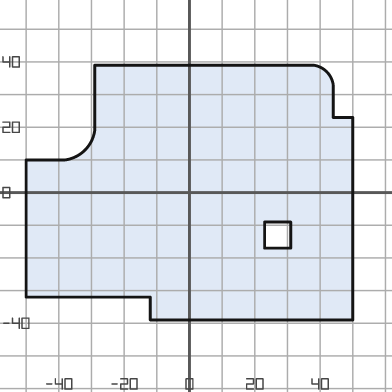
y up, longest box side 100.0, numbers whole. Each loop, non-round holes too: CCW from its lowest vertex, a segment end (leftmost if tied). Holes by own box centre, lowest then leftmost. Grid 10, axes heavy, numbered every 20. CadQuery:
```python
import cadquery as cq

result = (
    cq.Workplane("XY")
    .moveTo(-12.0, -39.0)
    .lineTo(50.0, -39.0)
    .lineTo(50.0, 23.0)
    .lineTo(44.0, 23.0)
    .lineTo(44.0, 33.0)
    .threePointArc((42.0, 37.0), (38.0, 39.0))
    .lineTo(-29.0, 39.0)
    .lineTo(-29.0, 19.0)
    .threePointArc((-32.0, 13.0), (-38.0, 10.0))
    .lineTo(-50.0, 10.0)
    .lineTo(-50.0, -32.0)
    .lineTo(-12.0, -32.0)
    .close()
    .moveTo(23.0, -17.0)
    .lineTo(31.0, -17.0)
    .lineTo(31.0, -9.0)
    .lineTo(23.0, -9.0)
    .close()
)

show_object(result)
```